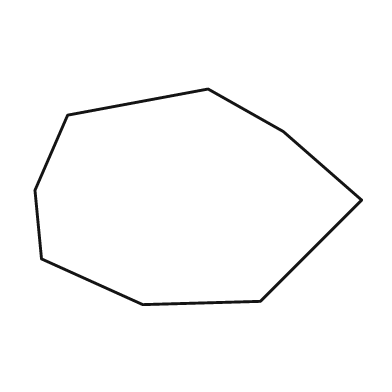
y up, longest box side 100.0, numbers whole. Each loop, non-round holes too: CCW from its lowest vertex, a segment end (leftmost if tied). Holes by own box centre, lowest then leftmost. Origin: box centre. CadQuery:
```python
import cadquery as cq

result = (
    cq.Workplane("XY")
    .moveTo(-17.0, -33.0)
    .lineTo(19.0, -32.0)
    .lineTo(50.0, -1.0)
    .lineTo(26.0, 20.0)
    .lineTo(3.0, 33.0)
    .lineTo(-40.0, 25.0)
    .lineTo(-50.0, 2.0)
    .lineTo(-48.0, -19.0)
    .close()
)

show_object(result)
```